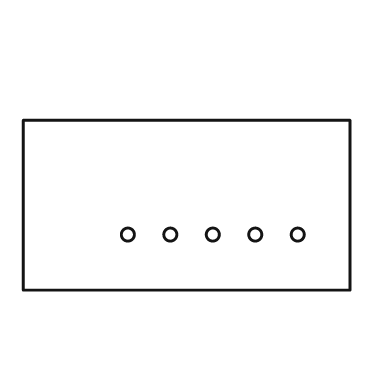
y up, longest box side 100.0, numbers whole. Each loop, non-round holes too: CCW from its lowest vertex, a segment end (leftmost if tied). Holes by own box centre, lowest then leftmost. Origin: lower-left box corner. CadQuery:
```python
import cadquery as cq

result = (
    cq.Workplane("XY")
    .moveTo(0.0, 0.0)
    .lineTo(100.0, 0.0)
    .lineTo(100.0, 52.0)
    .lineTo(0.0, 52.0)
    .close()
    .moveTo(32.0, 17.0)
    .circle(2.0)
    .moveTo(45.0, 17.0)
    .circle(2.0)
    .moveTo(58.0, 17.0)
    .circle(2.0)
    .moveTo(71.0, 17.0)
    .circle(2.0)
    .moveTo(84.0, 17.0)
    .circle(2.0)
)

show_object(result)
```